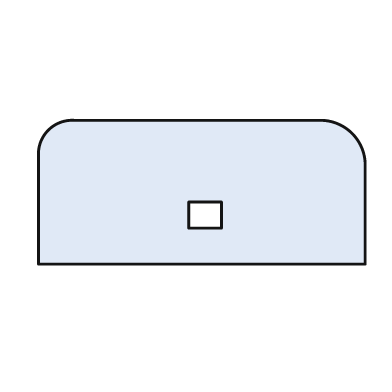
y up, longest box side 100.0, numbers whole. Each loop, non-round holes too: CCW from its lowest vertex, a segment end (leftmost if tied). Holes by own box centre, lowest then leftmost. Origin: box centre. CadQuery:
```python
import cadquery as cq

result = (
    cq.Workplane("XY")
    .moveTo(-50.0, -22.0)
    .lineTo(50.0, -22.0)
    .lineTo(50.0, 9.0)
    .threePointArc((46.0, 18.0), (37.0, 22.0))
    .lineTo(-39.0, 22.0)
    .threePointArc((-47.0, 19.0), (-50.0, 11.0))
    .close()
    .moveTo(-4.0, -11.0)
    .lineTo(6.0, -11.0)
    .lineTo(6.0, -3.0)
    .lineTo(-4.0, -3.0)
    .close()
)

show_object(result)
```